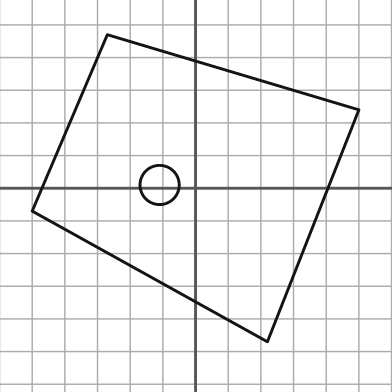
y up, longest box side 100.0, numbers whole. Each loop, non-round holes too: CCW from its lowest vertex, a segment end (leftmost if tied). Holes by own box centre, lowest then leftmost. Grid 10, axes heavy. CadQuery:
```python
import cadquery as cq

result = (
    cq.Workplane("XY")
    .moveTo(22.0, -47.0)
    .lineTo(50.0, 24.0)
    .lineTo(-27.0, 47.0)
    .lineTo(-50.0, -7.0)
    .close()
    .moveTo(-11.0, 1.0)
    .circle(6.0)
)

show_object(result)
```